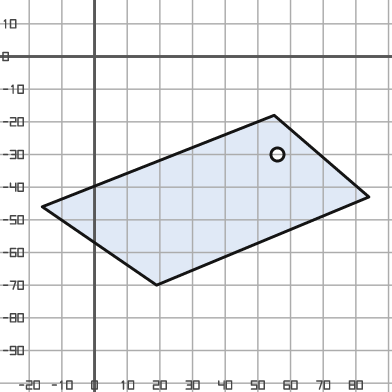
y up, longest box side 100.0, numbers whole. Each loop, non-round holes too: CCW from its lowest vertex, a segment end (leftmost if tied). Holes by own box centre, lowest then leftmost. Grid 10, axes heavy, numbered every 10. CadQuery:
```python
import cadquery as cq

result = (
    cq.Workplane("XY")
    .moveTo(19.0, -70.0)
    .lineTo(84.0, -43.0)
    .lineTo(55.0, -18.0)
    .lineTo(-16.0, -46.0)
    .close()
    .moveTo(56.0, -30.0)
    .circle(2.0)
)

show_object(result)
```